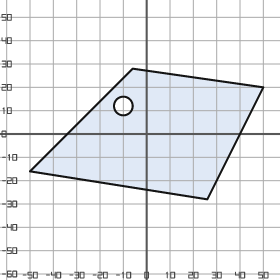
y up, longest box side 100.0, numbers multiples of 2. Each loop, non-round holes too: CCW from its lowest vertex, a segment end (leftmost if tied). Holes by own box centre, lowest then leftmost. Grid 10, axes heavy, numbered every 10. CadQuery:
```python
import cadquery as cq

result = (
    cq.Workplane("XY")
    .moveTo(26.0, -28.0)
    .lineTo(50.0, 20.0)
    .lineTo(-6.0, 28.0)
    .lineTo(-50.0, -16.0)
    .close()
    .moveTo(-10.0, 12.0)
    .circle(4.0)
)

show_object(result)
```